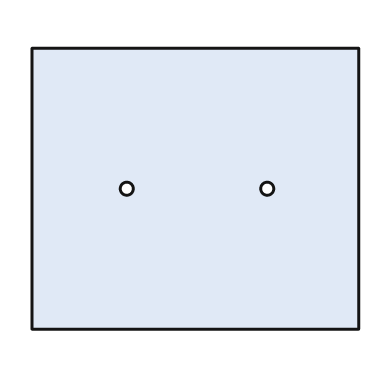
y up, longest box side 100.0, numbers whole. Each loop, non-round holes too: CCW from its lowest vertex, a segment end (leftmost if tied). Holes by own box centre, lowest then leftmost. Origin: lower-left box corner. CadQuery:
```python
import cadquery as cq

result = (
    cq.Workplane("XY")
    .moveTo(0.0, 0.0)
    .lineTo(100.0, 0.0)
    .lineTo(100.0, 86.0)
    .lineTo(0.0, 86.0)
    .close()
    .moveTo(29.0, 43.0)
    .circle(2.0)
    .moveTo(72.0, 43.0)
    .circle(2.0)
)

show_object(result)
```